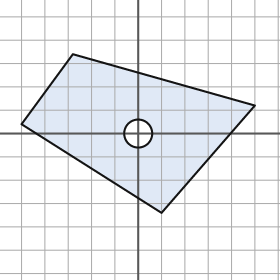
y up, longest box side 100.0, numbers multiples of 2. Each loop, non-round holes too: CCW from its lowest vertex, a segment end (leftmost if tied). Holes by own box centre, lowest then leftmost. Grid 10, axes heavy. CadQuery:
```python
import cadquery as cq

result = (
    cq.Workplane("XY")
    .moveTo(10.0, -34.0)
    .lineTo(50.0, 12.0)
    .lineTo(-28.0, 34.0)
    .lineTo(-50.0, 4.0)
    .close()
    .moveTo(0.0, 0.0)
    .circle(6.0)
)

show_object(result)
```